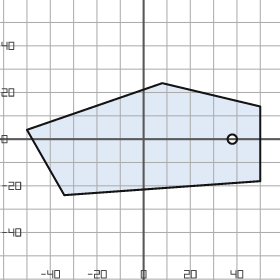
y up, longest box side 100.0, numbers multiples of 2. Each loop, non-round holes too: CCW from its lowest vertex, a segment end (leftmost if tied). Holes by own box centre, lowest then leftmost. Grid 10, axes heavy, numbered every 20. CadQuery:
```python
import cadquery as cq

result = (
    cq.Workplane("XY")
    .moveTo(-34.0, -24.0)
    .lineTo(50.0, -18.0)
    .lineTo(50.0, 14.0)
    .lineTo(8.0, 24.0)
    .lineTo(-50.0, 4.0)
    .close()
    .moveTo(38.0, 0.0)
    .circle(2.0)
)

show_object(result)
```